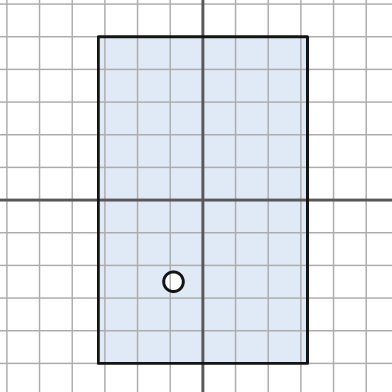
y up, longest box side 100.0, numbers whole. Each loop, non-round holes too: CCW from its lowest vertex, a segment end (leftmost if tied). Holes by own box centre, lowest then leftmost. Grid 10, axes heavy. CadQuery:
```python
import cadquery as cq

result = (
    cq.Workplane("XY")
    .moveTo(-32.0, -50.0)
    .lineTo(32.0, -50.0)
    .lineTo(32.0, 50.0)
    .lineTo(-32.0, 50.0)
    .close()
    .moveTo(-9.0, -25.0)
    .circle(3.0)
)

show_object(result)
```